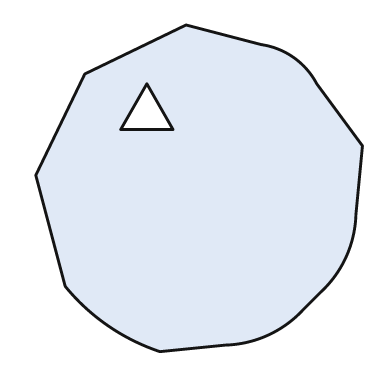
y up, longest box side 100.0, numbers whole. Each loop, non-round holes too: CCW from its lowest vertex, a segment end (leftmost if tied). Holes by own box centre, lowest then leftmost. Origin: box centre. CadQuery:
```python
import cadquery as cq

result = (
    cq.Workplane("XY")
    .moveTo(-12.0, -50.0)
    .lineTo(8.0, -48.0)
    .threePointArc((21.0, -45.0), (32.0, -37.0))
    .lineTo(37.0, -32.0)
    .threePointArc((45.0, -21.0), (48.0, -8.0))
    .lineTo(50.0, 13.0)
    .lineTo(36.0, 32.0)
    .threePointArc((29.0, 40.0), (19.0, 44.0))
    .lineTo(-4.0, 50.0)
    .lineTo(-35.0, 35.0)
    .lineTo(-50.0, 4.0)
    .lineTo(-41.0, -30.0)
    .threePointArc((-28.0, -42.0), (-12.0, -50.0))
    .close()
    .moveTo(-24.0, 18.0)
    .lineTo(-8.0, 18.0)
    .lineTo(-16.0, 32.0)
    .close()
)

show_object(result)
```